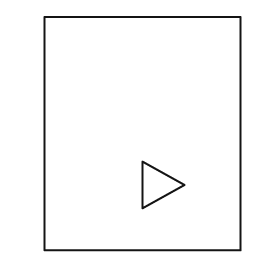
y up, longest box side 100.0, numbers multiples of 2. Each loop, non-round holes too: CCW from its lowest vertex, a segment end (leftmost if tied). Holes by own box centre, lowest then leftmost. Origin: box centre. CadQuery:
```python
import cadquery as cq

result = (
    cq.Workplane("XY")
    .moveTo(-42.0, -50.0)
    .lineTo(42.0, -50.0)
    .lineTo(42.0, 50.0)
    .lineTo(-42.0, 50.0)
    .close()
    .moveTo(0.0, -32.0)
    .lineTo(18.0, -22.0)
    .lineTo(0.0, -12.0)
    .close()
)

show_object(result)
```